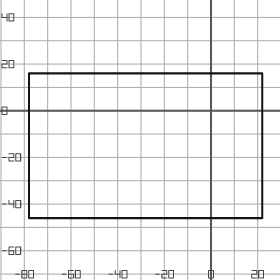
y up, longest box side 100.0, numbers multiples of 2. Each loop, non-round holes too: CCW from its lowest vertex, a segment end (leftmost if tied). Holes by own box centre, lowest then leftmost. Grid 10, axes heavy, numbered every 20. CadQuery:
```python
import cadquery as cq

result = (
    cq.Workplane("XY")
    .moveTo(-78.0, -46.0)
    .lineTo(22.0, -46.0)
    .lineTo(22.0, 16.0)
    .lineTo(-78.0, 16.0)
    .close()
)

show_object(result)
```